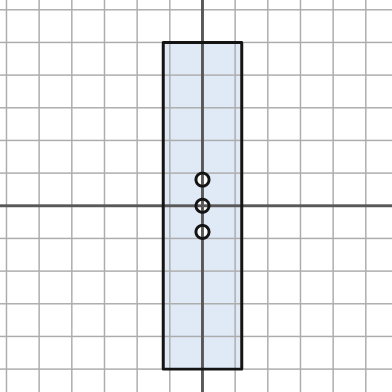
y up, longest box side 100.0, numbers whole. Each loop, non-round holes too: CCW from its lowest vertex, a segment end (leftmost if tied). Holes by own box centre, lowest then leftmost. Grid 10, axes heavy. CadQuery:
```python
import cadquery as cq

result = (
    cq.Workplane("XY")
    .moveTo(-12.0, -50.0)
    .lineTo(12.0, -50.0)
    .lineTo(12.0, 50.0)
    .lineTo(-12.0, 50.0)
    .close()
    .moveTo(0.0, -8.0)
    .circle(2.0)
    .moveTo(0.0, 0.0)
    .circle(2.0)
    .moveTo(0.0, 8.0)
    .circle(2.0)
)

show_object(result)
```